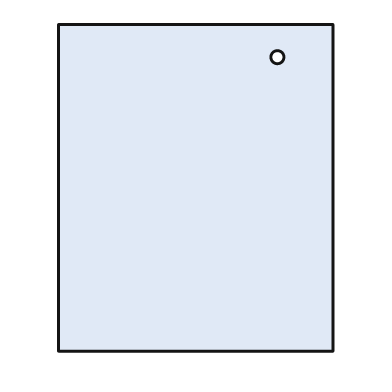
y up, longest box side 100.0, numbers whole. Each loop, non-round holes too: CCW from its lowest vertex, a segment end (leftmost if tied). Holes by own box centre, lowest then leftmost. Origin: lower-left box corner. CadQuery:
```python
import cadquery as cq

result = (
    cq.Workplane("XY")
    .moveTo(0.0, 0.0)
    .lineTo(84.0, 0.0)
    .lineTo(84.0, 100.0)
    .lineTo(0.0, 100.0)
    .close()
    .moveTo(67.0, 90.0)
    .circle(2.0)
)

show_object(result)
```